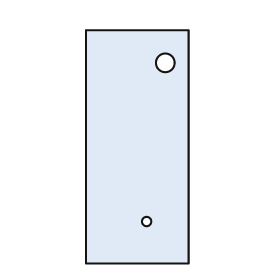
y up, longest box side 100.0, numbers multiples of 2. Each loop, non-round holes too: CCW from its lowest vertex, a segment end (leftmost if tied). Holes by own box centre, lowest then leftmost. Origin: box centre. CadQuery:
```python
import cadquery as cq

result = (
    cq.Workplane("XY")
    .moveTo(-22.0, -50.0)
    .lineTo(22.0, -50.0)
    .lineTo(22.0, 50.0)
    .lineTo(-22.0, 50.0)
    .close()
    .moveTo(4.0, -32.0)
    .circle(2.0)
    .moveTo(12.0, 36.0)
    .circle(4.0)
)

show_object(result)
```